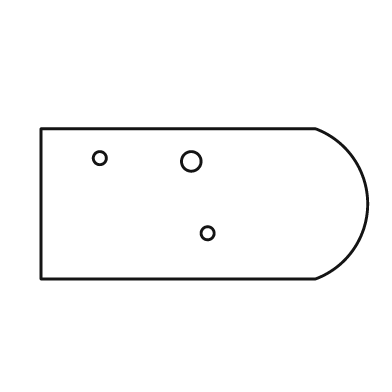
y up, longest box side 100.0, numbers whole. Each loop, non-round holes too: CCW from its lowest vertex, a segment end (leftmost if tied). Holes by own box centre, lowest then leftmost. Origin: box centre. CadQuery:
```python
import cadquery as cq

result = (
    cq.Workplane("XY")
    .moveTo(-50.0, -23.0)
    .lineTo(34.0, -23.0)
    .threePointArc((50.0, 0.0), (34.0, 23.0))
    .lineTo(-50.0, 23.0)
    .close()
    .moveTo(1.0, -9.0)
    .circle(2.0)
    .moveTo(-4.0, 13.0)
    .circle(3.0)
    .moveTo(-32.0, 14.0)
    .circle(2.0)
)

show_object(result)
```